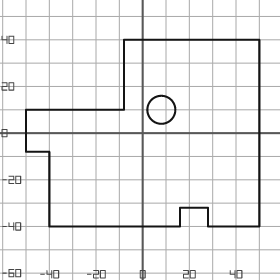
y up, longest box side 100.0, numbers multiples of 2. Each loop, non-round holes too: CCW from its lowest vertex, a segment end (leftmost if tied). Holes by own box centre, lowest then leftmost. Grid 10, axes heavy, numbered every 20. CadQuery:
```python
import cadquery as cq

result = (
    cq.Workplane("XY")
    .moveTo(-40.0, -40.0)
    .lineTo(16.0, -40.0)
    .lineTo(16.0, -32.0)
    .lineTo(28.0, -32.0)
    .lineTo(28.0, -40.0)
    .lineTo(50.0, -40.0)
    .lineTo(50.0, 40.0)
    .lineTo(-8.0, 40.0)
    .lineTo(-8.0, 10.0)
    .lineTo(-50.0, 10.0)
    .lineTo(-50.0, -8.0)
    .lineTo(-40.0, -8.0)
    .close()
    .moveTo(8.0, 10.0)
    .circle(6.0)
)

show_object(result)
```